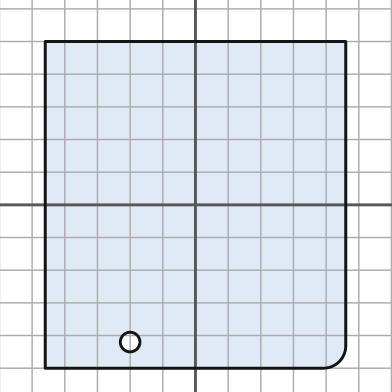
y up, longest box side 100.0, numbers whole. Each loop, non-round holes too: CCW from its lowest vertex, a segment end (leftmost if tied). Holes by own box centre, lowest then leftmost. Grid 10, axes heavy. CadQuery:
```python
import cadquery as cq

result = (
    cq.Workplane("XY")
    .moveTo(-46.0, -50.0)
    .lineTo(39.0, -50.0)
    .threePointArc((44.0, -48.0), (46.0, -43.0))
    .lineTo(46.0, 50.0)
    .lineTo(-46.0, 50.0)
    .close()
    .moveTo(-20.0, -42.0)
    .circle(3.0)
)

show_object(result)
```